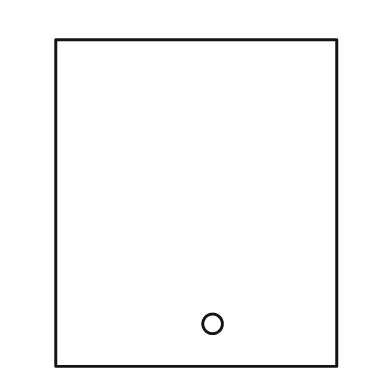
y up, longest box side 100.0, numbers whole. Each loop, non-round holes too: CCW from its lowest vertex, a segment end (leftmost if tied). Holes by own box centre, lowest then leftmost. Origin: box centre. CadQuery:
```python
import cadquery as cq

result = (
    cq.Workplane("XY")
    .moveTo(-43.0, -50.0)
    .lineTo(43.0, -50.0)
    .lineTo(43.0, 50.0)
    .lineTo(-43.0, 50.0)
    .close()
    .moveTo(5.0, -37.0)
    .circle(3.0)
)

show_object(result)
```